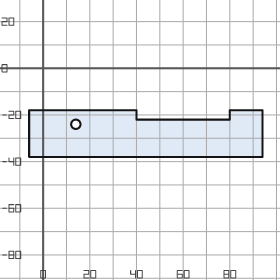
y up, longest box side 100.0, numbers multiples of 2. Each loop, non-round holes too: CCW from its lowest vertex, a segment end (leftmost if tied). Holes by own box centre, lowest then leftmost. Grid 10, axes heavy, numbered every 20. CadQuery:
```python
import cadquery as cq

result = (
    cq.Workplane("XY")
    .moveTo(-6.0, -38.0)
    .lineTo(94.0, -38.0)
    .lineTo(94.0, -18.0)
    .lineTo(80.0, -18.0)
    .lineTo(80.0, -22.0)
    .lineTo(40.0, -22.0)
    .lineTo(40.0, -18.0)
    .lineTo(-6.0, -18.0)
    .close()
    .moveTo(14.0, -24.0)
    .circle(2.0)
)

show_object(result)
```